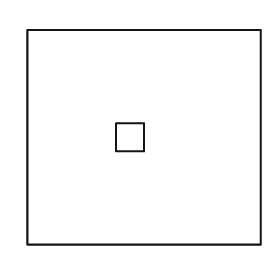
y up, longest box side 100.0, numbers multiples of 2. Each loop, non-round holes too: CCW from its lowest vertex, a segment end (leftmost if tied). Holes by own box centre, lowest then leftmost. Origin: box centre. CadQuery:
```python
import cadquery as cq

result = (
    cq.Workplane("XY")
    .moveTo(-50.0, -46.0)
    .lineTo(50.0, -46.0)
    .lineTo(50.0, 46.0)
    .lineTo(-50.0, 46.0)
    .close()
    .moveTo(-12.0, -6.0)
    .lineTo(0.0, -6.0)
    .lineTo(0.0, 6.0)
    .lineTo(-12.0, 6.0)
    .close()
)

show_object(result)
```